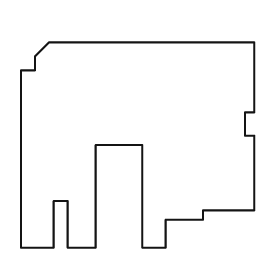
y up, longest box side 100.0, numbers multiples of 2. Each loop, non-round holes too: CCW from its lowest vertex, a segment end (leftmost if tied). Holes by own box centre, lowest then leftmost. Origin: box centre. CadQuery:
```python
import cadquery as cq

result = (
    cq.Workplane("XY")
    .moveTo(-50.0, -44.0)
    .lineTo(-36.0, -44.0)
    .lineTo(-36.0, -24.0)
    .lineTo(-30.0, -24.0)
    .lineTo(-30.0, -44.0)
    .lineTo(-18.0, -44.0)
    .lineTo(-18.0, 0.0)
    .lineTo(2.0, 0.0)
    .lineTo(2.0, -44.0)
    .lineTo(12.0, -44.0)
    .lineTo(12.0, -32.0)
    .lineTo(28.0, -32.0)
    .lineTo(28.0, -28.0)
    .lineTo(50.0, -28.0)
    .lineTo(50.0, 4.0)
    .lineTo(46.0, 4.0)
    .lineTo(46.0, 14.0)
    .lineTo(50.0, 14.0)
    .lineTo(50.0, 44.0)
    .lineTo(-38.0, 44.0)
    .lineTo(-44.0, 38.0)
    .lineTo(-44.0, 32.0)
    .lineTo(-50.0, 32.0)
    .close()
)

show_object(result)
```